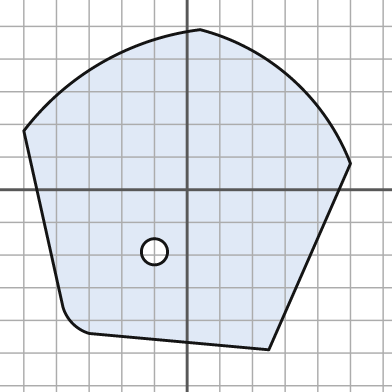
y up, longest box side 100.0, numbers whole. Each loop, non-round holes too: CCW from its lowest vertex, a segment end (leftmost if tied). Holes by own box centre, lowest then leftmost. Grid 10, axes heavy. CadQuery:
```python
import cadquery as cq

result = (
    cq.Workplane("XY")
    .moveTo(25.0, -49.0)
    .lineTo(50.0, 8.0)
    .threePointArc((32.0, 34.0), (4.0, 49.0))
    .threePointArc((-26.0, 39.0), (-50.0, 18.0))
    .lineTo(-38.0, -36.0)
    .threePointArc((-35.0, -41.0), (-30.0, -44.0))
    .close()
    .moveTo(-10.0, -19.0)
    .circle(4.0)
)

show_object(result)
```